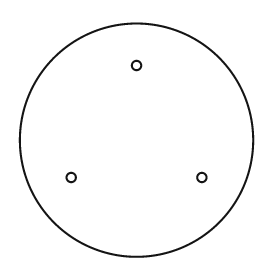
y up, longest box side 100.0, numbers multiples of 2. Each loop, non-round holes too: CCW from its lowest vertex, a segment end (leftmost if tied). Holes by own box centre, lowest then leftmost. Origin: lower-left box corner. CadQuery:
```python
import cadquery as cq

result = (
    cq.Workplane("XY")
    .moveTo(50.0, 50.0)
    .circle(50.0)
    .moveTo(22.0, 34.0)
    .circle(2.0)
    .moveTo(78.0, 34.0)
    .circle(2.0)
    .moveTo(50.0, 82.0)
    .circle(2.0)
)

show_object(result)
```